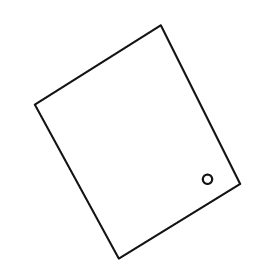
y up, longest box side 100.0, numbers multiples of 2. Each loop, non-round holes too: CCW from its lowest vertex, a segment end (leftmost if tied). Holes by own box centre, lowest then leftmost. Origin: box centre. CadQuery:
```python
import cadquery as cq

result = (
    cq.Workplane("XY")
    .moveTo(-8.0, -50.0)
    .lineTo(44.0, -18.0)
    .lineTo(10.0, 50.0)
    .lineTo(-44.0, 16.0)
    .close()
    .moveTo(30.0, -16.0)
    .circle(2.0)
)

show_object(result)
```